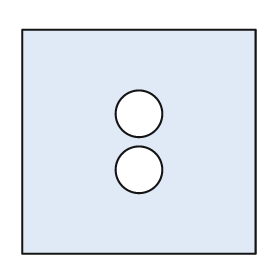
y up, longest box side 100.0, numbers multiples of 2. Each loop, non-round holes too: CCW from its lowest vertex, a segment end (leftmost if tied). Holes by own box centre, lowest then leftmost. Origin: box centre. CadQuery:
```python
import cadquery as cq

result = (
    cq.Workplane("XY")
    .moveTo(-50.0, -48.0)
    .lineTo(50.0, -48.0)
    .lineTo(50.0, 48.0)
    .lineTo(-50.0, 48.0)
    .close()
    .moveTo(0.0, -12.0)
    .circle(10.0)
    .moveTo(0.0, 12.0)
    .circle(10.0)
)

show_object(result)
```